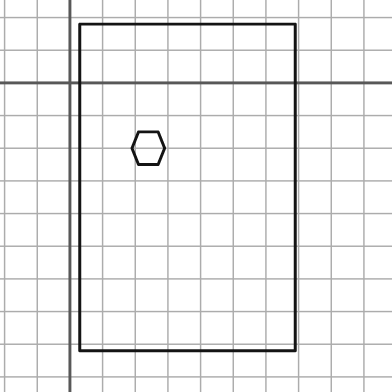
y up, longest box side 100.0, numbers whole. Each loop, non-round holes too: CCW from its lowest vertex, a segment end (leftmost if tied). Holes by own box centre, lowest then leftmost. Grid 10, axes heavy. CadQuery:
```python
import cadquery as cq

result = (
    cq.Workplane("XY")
    .moveTo(3.0, -82.0)
    .lineTo(69.0, -82.0)
    .lineTo(69.0, 18.0)
    .lineTo(3.0, 18.0)
    .close()
    .moveTo(21.0, -25.0)
    .lineTo(27.0, -25.0)
    .lineTo(29.0, -20.0)
    .lineTo(27.0, -15.0)
    .lineTo(21.0, -15.0)
    .lineTo(19.0, -20.0)
    .close()
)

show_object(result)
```